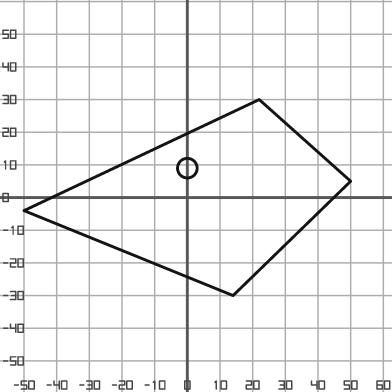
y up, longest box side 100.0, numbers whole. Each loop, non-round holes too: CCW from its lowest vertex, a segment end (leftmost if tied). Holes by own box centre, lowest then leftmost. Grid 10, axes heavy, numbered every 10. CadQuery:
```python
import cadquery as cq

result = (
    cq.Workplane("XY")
    .moveTo(14.0, -30.0)
    .lineTo(50.0, 5.0)
    .lineTo(22.0, 30.0)
    .lineTo(-50.0, -4.0)
    .close()
    .moveTo(0.0, 9.0)
    .circle(3.0)
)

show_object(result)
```